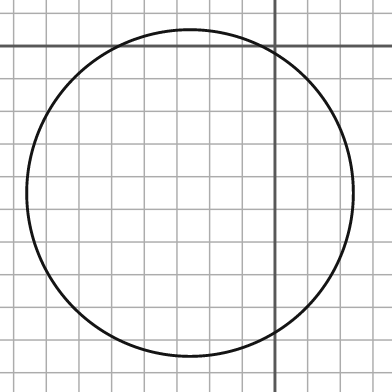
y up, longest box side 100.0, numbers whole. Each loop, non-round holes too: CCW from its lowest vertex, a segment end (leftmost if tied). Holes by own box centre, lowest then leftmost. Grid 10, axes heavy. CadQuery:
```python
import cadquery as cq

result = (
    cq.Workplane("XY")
    .moveTo(-26.0, -45.0)
    .circle(50.0)
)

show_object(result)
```